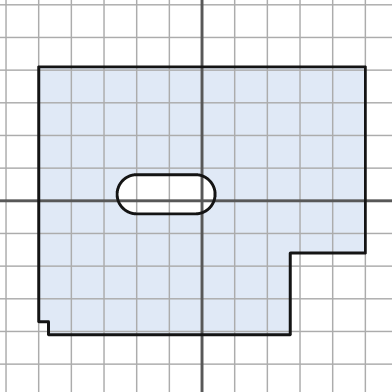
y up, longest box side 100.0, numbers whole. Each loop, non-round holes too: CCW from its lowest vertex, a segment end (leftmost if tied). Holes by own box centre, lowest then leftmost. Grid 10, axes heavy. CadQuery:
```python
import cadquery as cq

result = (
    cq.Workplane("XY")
    .moveTo(-47.0, -41.0)
    .lineTo(27.0, -41.0)
    .lineTo(27.0, -16.0)
    .lineTo(50.0, -16.0)
    .lineTo(50.0, 41.0)
    .lineTo(-50.0, 41.0)
    .lineTo(-50.0, -37.0)
    .lineTo(-47.0, -37.0)
    .close()
    .moveTo(-20.0, -4.0)
    .lineTo(-2.0, -4.0)
    .threePointArc((4.0, 2.0), (-2.0, 8.0))
    .lineTo(-20.0, 8.0)
    .threePointArc((-26.0, 2.0), (-20.0, -4.0))
    .close()
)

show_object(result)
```